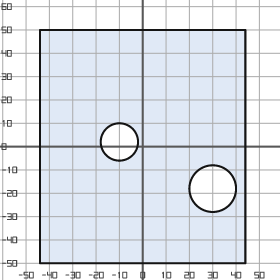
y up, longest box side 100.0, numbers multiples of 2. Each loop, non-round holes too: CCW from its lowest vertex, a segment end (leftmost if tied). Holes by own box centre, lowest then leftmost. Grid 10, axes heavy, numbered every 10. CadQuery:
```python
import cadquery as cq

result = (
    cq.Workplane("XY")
    .moveTo(-44.0, -50.0)
    .lineTo(44.0, -50.0)
    .lineTo(44.0, 50.0)
    .lineTo(-44.0, 50.0)
    .close()
    .moveTo(30.0, -18.0)
    .circle(10.0)
    .moveTo(-10.0, 2.0)
    .circle(8.0)
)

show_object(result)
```